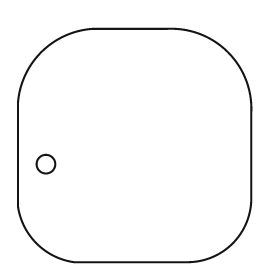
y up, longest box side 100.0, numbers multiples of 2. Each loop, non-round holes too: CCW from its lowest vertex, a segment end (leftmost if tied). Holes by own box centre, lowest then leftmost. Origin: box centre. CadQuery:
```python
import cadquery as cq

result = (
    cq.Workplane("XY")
    .moveTo(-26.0, -50.0)
    .lineTo(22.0, -50.0)
    .threePointArc((42.0, -42.0), (50.0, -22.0))
    .lineTo(50.0, 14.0)
    .threePointArc((40.0, 40.0), (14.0, 50.0))
    .lineTo(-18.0, 50.0)
    .threePointArc((-40.0, 40.0), (-50.0, 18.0))
    .lineTo(-50.0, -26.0)
    .threePointArc((-42.0, -42.0), (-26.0, -50.0))
    .close()
    .moveTo(-38.0, -8.0)
    .circle(4.0)
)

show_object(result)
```